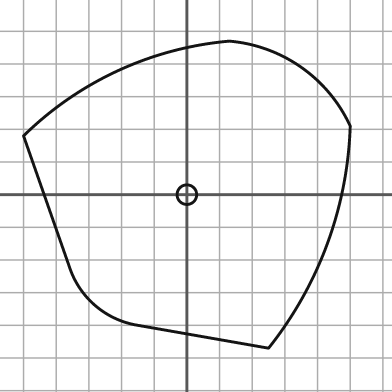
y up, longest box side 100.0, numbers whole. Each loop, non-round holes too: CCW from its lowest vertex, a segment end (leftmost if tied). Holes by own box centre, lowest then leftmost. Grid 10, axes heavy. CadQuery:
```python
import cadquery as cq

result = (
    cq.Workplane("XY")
    .moveTo(25.0, -47.0)
    .threePointArc((43.0, -15.0), (50.0, 21.0))
    .threePointArc((35.0, 39.0), (13.0, 47.0))
    .threePointArc((-21.0, 38.0), (-50.0, 18.0))
    .lineTo(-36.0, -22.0)
    .threePointArc((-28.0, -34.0), (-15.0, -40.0))
    .close()
    .moveTo(0.0, 0.0)
    .circle(3.0)
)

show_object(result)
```